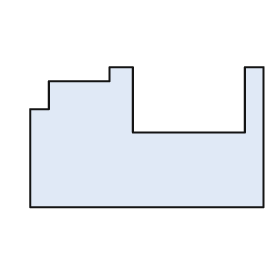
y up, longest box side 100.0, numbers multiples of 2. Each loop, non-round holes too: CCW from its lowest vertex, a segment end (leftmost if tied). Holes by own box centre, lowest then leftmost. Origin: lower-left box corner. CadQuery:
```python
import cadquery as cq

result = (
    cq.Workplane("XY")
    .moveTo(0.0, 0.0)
    .lineTo(100.0, 0.0)
    .lineTo(100.0, 60.0)
    .lineTo(92.0, 60.0)
    .lineTo(92.0, 32.0)
    .lineTo(44.0, 32.0)
    .lineTo(44.0, 60.0)
    .lineTo(34.0, 60.0)
    .lineTo(34.0, 54.0)
    .lineTo(8.0, 54.0)
    .lineTo(8.0, 42.0)
    .lineTo(0.0, 42.0)
    .close()
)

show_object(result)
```